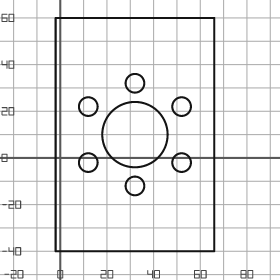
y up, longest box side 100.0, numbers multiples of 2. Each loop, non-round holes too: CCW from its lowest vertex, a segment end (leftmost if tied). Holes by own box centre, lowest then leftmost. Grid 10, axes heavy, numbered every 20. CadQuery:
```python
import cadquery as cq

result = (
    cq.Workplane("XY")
    .moveTo(-2.0, -40.0)
    .lineTo(66.0, -40.0)
    .lineTo(66.0, 60.0)
    .lineTo(-2.0, 60.0)
    .close()
    .moveTo(32.0, -12.0)
    .circle(4.0)
    .moveTo(12.0, -2.0)
    .circle(4.0)
    .moveTo(52.0, -2.0)
    .circle(4.0)
    .moveTo(32.0, 10.0)
    .circle(14.0)
    .moveTo(12.0, 22.0)
    .circle(4.0)
    .moveTo(52.0, 22.0)
    .circle(4.0)
    .moveTo(32.0, 32.0)
    .circle(4.0)
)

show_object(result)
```